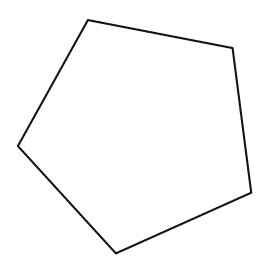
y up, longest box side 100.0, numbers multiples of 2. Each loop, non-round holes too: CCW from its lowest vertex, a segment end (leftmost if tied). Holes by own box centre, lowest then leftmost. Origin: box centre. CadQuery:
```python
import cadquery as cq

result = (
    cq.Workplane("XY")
    .moveTo(-8.0, -50.0)
    .lineTo(50.0, -24.0)
    .lineTo(42.0, 38.0)
    .lineTo(-20.0, 50.0)
    .lineTo(-50.0, -4.0)
    .close()
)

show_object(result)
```